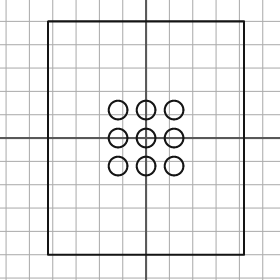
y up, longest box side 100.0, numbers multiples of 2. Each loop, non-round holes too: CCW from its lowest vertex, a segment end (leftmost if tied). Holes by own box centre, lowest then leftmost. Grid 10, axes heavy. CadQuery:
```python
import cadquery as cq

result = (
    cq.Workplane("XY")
    .moveTo(-42.0, -50.0)
    .lineTo(42.0, -50.0)
    .lineTo(42.0, 50.0)
    .lineTo(-42.0, 50.0)
    .close()
    .moveTo(-12.0, -12.0)
    .circle(4.0)
    .moveTo(0.0, -12.0)
    .circle(4.0)
    .moveTo(12.0, -12.0)
    .circle(4.0)
    .moveTo(-12.0, 0.0)
    .circle(4.0)
    .moveTo(0.0, 0.0)
    .circle(4.0)
    .moveTo(12.0, 0.0)
    .circle(4.0)
    .moveTo(-12.0, 12.0)
    .circle(4.0)
    .moveTo(0.0, 12.0)
    .circle(4.0)
    .moveTo(12.0, 12.0)
    .circle(4.0)
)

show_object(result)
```